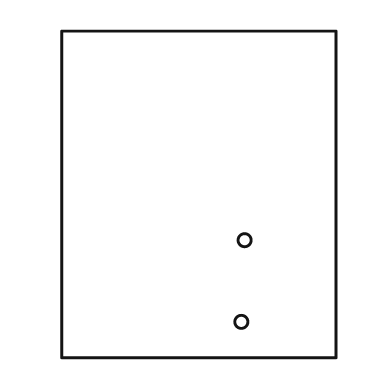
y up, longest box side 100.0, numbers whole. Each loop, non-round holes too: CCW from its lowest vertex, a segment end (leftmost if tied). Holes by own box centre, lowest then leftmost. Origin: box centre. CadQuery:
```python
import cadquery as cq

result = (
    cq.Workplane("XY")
    .moveTo(-42.0, -50.0)
    .lineTo(42.0, -50.0)
    .lineTo(42.0, 50.0)
    .lineTo(-42.0, 50.0)
    .close()
    .moveTo(13.0, -39.0)
    .circle(2.0)
    .moveTo(14.0, -14.0)
    .circle(2.0)
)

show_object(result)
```